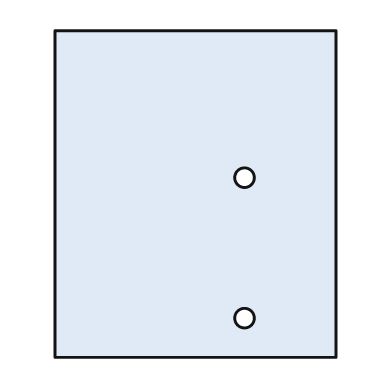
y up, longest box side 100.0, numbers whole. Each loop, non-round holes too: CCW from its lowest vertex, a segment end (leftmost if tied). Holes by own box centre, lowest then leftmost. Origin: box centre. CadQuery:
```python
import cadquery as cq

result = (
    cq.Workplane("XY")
    .moveTo(-43.0, -50.0)
    .lineTo(43.0, -50.0)
    .lineTo(43.0, 50.0)
    .lineTo(-43.0, 50.0)
    .close()
    .moveTo(15.0, -38.0)
    .circle(3.0)
    .moveTo(15.0, 5.0)
    .circle(3.0)
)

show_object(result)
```